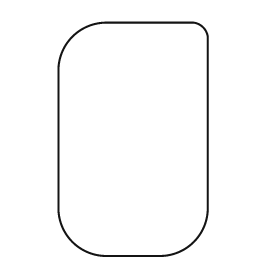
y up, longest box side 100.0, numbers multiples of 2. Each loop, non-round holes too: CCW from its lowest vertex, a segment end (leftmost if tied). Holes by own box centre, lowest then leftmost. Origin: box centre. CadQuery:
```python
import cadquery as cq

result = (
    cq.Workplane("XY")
    .moveTo(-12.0, -50.0)
    .lineTo(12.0, -50.0)
    .threePointArc((26.0, -44.0), (32.0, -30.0))
    .lineTo(32.0, 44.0)
    .threePointArc((30.0, 48.0), (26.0, 50.0))
    .lineTo(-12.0, 50.0)
    .threePointArc((-26.0, 44.0), (-32.0, 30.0))
    .lineTo(-32.0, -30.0)
    .threePointArc((-26.0, -44.0), (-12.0, -50.0))
    .close()
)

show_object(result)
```